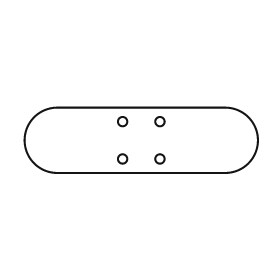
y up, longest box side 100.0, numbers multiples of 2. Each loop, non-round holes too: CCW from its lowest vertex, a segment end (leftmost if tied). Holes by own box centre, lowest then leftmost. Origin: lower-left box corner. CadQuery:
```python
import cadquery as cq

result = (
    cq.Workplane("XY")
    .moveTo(14.0, 0.0)
    .lineTo(86.0, 0.0)
    .threePointArc((100.0, 14.0), (86.0, 28.0))
    .lineTo(14.0, 28.0)
    .threePointArc((0.0, 14.0), (14.0, 0.0))
    .close()
    .moveTo(42.0, 6.0)
    .circle(2.0)
    .moveTo(58.0, 6.0)
    .circle(2.0)
    .moveTo(42.0, 22.0)
    .circle(2.0)
    .moveTo(58.0, 22.0)
    .circle(2.0)
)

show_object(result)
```